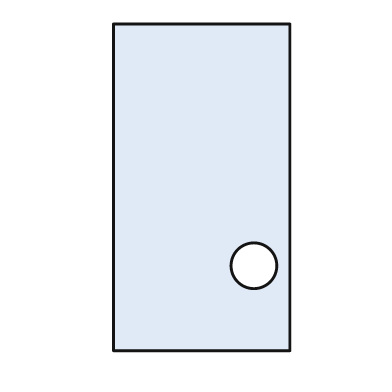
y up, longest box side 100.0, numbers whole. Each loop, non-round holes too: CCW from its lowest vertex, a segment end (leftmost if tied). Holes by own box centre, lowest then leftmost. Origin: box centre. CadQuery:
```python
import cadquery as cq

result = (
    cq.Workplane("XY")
    .moveTo(-27.0, -50.0)
    .lineTo(27.0, -50.0)
    .lineTo(27.0, 50.0)
    .lineTo(-27.0, 50.0)
    .close()
    .moveTo(16.0, -24.0)
    .circle(7.0)
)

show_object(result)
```